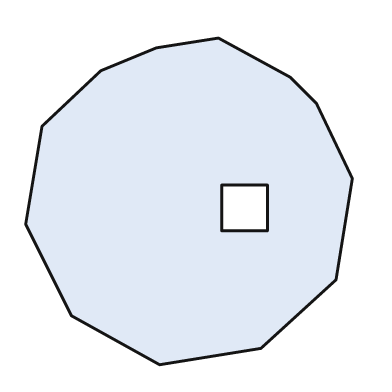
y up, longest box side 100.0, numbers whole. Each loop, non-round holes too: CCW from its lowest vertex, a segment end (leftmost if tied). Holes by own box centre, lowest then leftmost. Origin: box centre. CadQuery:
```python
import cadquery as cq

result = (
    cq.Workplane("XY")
    .moveTo(-9.0, -50.0)
    .lineTo(22.0, -45.0)
    .lineTo(45.0, -24.0)
    .lineTo(50.0, 7.0)
    .lineTo(39.0, 30.0)
    .lineTo(31.0, 38.0)
    .lineTo(9.0, 50.0)
    .lineTo(-10.0, 47.0)
    .lineTo(-27.0, 40.0)
    .lineTo(-45.0, 23.0)
    .lineTo(-50.0, -7.0)
    .lineTo(-36.0, -35.0)
    .close()
    .moveTo(10.0, -9.0)
    .lineTo(24.0, -9.0)
    .lineTo(24.0, 5.0)
    .lineTo(10.0, 5.0)
    .close()
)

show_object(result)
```